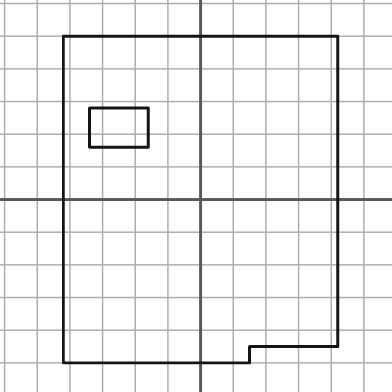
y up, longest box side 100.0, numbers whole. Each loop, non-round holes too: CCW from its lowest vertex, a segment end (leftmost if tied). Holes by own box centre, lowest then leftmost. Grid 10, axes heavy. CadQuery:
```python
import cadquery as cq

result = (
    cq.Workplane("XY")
    .moveTo(-42.0, -50.0)
    .lineTo(15.0, -50.0)
    .lineTo(15.0, -45.0)
    .lineTo(42.0, -45.0)
    .lineTo(42.0, 50.0)
    .lineTo(-42.0, 50.0)
    .close()
    .moveTo(-34.0, 16.0)
    .lineTo(-16.0, 16.0)
    .lineTo(-16.0, 28.0)
    .lineTo(-34.0, 28.0)
    .close()
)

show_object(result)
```